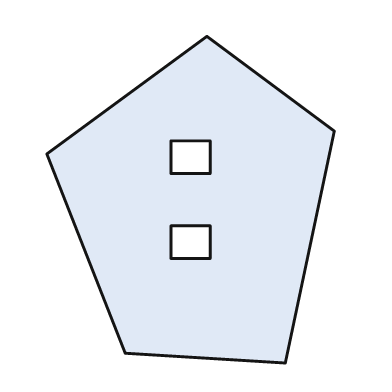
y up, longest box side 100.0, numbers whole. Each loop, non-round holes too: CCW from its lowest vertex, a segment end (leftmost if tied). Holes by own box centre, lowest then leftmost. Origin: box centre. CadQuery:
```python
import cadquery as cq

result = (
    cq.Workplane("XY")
    .moveTo(29.0, -50.0)
    .lineTo(44.0, 21.0)
    .lineTo(5.0, 50.0)
    .lineTo(-44.0, 14.0)
    .lineTo(-20.0, -47.0)
    .close()
    .moveTo(-6.0, -18.0)
    .lineTo(6.0, -18.0)
    .lineTo(6.0, -8.0)
    .lineTo(-6.0, -8.0)
    .close()
    .moveTo(-6.0, 8.0)
    .lineTo(6.0, 8.0)
    .lineTo(6.0, 18.0)
    .lineTo(-6.0, 18.0)
    .close()
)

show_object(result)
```